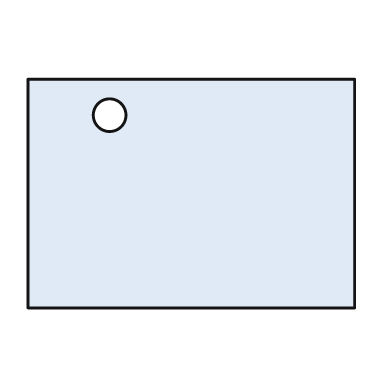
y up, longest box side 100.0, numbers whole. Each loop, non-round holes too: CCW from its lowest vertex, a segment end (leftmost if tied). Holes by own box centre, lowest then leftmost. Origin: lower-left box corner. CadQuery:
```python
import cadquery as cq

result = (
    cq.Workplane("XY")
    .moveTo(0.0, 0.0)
    .lineTo(100.0, 0.0)
    .lineTo(100.0, 70.0)
    .lineTo(0.0, 70.0)
    .close()
    .moveTo(25.0, 59.0)
    .circle(5.0)
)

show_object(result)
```